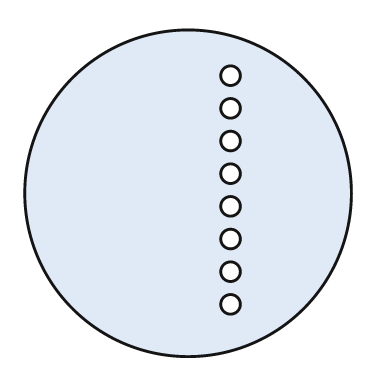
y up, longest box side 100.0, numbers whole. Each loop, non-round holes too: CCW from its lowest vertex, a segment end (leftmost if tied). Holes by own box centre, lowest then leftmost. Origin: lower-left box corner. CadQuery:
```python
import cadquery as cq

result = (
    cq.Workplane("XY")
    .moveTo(50.0, 50.0)
    .circle(50.0)
    .moveTo(63.0, 16.0)
    .circle(3.0)
    .moveTo(63.0, 26.0)
    .circle(3.0)
    .moveTo(63.0, 36.0)
    .circle(3.0)
    .moveTo(63.0, 46.0)
    .circle(3.0)
    .moveTo(63.0, 56.0)
    .circle(3.0)
    .moveTo(63.0, 66.0)
    .circle(3.0)
    .moveTo(63.0, 76.0)
    .circle(3.0)
    .moveTo(63.0, 86.0)
    .circle(3.0)
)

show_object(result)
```